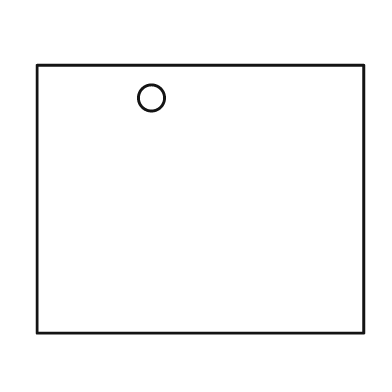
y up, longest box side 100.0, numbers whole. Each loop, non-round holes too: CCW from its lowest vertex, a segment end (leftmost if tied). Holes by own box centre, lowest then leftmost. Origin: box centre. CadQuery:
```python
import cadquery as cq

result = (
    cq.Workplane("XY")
    .moveTo(-50.0, -41.0)
    .lineTo(50.0, -41.0)
    .lineTo(50.0, 41.0)
    .lineTo(-50.0, 41.0)
    .close()
    .moveTo(-15.0, 31.0)
    .circle(4.0)
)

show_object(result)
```